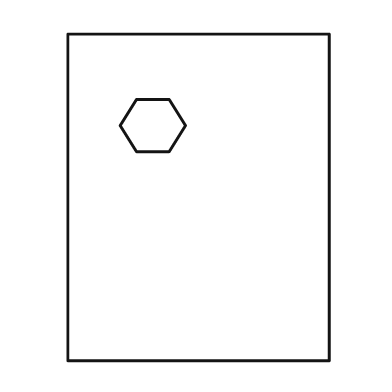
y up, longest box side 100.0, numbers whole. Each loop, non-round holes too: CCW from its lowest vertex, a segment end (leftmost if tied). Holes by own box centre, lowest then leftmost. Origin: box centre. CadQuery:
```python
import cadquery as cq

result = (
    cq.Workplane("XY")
    .moveTo(-40.0, -50.0)
    .lineTo(40.0, -50.0)
    .lineTo(40.0, 50.0)
    .lineTo(-40.0, 50.0)
    .close()
    .moveTo(-19.0, 14.0)
    .lineTo(-9.0, 14.0)
    .lineTo(-4.0, 22.0)
    .lineTo(-9.0, 30.0)
    .lineTo(-19.0, 30.0)
    .lineTo(-24.0, 22.0)
    .close()
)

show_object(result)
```